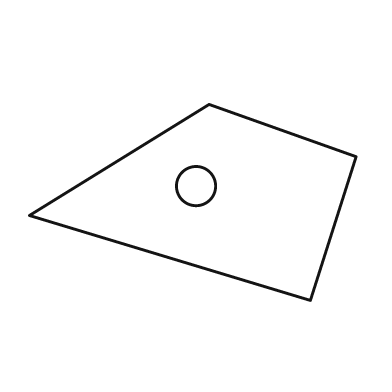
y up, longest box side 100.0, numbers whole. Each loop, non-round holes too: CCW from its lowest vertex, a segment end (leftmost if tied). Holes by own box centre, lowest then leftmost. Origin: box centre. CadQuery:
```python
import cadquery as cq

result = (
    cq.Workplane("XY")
    .moveTo(36.0, -30.0)
    .lineTo(50.0, 14.0)
    .lineTo(5.0, 30.0)
    .lineTo(-50.0, -4.0)
    .close()
    .moveTo(1.0, 5.0)
    .circle(6.0)
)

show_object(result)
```